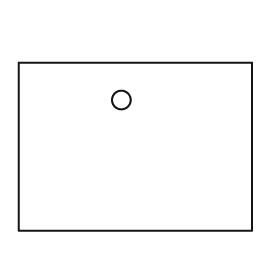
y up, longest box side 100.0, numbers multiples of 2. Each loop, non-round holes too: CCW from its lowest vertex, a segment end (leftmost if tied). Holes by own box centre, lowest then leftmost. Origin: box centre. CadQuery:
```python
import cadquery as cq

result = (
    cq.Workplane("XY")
    .moveTo(-50.0, -36.0)
    .lineTo(50.0, -36.0)
    .lineTo(50.0, 36.0)
    .lineTo(-50.0, 36.0)
    .close()
    .moveTo(-6.0, 20.0)
    .circle(4.0)
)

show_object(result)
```